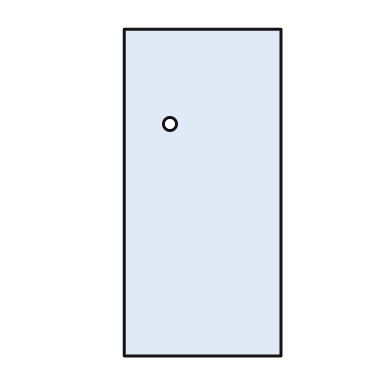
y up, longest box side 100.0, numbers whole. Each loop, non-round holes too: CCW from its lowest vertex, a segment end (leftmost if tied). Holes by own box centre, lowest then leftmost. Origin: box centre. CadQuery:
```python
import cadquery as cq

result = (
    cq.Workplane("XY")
    .moveTo(-24.0, -50.0)
    .lineTo(24.0, -50.0)
    .lineTo(24.0, 50.0)
    .lineTo(-24.0, 50.0)
    .close()
    .moveTo(-10.0, 21.0)
    .circle(2.0)
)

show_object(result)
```